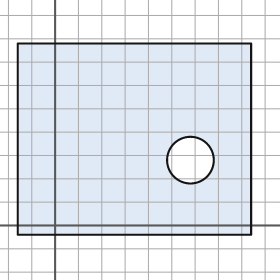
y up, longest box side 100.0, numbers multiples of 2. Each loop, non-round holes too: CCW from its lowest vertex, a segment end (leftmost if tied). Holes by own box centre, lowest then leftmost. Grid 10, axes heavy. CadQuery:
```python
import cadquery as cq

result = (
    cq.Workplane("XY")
    .moveTo(-16.0, -4.0)
    .lineTo(84.0, -4.0)
    .lineTo(84.0, 78.0)
    .lineTo(-16.0, 78.0)
    .close()
    .moveTo(58.0, 28.0)
    .circle(10.0)
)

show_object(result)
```